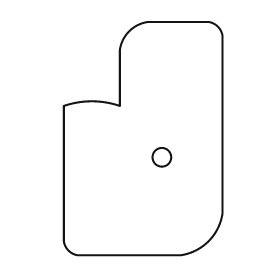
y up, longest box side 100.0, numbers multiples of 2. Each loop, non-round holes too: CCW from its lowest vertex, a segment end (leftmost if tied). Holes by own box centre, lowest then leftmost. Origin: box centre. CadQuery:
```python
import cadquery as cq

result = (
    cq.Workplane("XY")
    .moveTo(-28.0, -50.0)
    .lineTo(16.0, -50.0)
    .threePointArc((28.0, -44.0), (34.0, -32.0))
    .lineTo(34.0, 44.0)
    .threePointArc((32.0, 48.0), (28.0, 50.0))
    .lineTo(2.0, 50.0)
    .threePointArc((-6.0, 46.0), (-10.0, 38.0))
    .lineTo(-10.0, 14.0)
    .threePointArc((-22.0, 16.0), (-34.0, 14.0))
    .lineTo(-34.0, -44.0)
    .threePointArc((-32.0, -48.0), (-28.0, -50.0))
    .close()
    .moveTo(8.0, -8.0)
    .circle(4.0)
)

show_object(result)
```